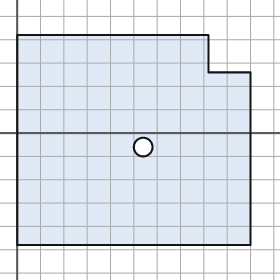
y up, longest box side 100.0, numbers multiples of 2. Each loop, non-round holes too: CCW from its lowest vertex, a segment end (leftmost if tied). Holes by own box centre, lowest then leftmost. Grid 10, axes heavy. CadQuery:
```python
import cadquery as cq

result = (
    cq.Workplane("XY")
    .moveTo(0.0, -48.0)
    .lineTo(100.0, -48.0)
    .lineTo(100.0, 26.0)
    .lineTo(82.0, 26.0)
    .lineTo(82.0, 42.0)
    .lineTo(0.0, 42.0)
    .close()
    .moveTo(54.0, -6.0)
    .circle(4.0)
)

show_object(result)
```